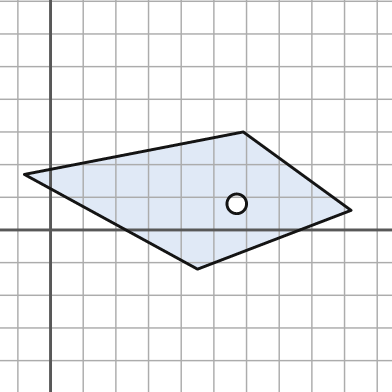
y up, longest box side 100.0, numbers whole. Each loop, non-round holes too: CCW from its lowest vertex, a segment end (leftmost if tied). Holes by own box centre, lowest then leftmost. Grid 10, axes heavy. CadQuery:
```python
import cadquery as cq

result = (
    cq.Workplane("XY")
    .moveTo(45.0, -12.0)
    .lineTo(92.0, 6.0)
    .lineTo(59.0, 30.0)
    .lineTo(-8.0, 17.0)
    .close()
    .moveTo(57.0, 8.0)
    .circle(3.0)
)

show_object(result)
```